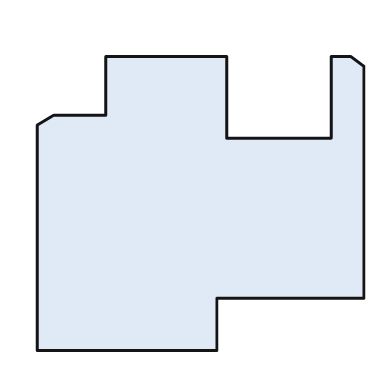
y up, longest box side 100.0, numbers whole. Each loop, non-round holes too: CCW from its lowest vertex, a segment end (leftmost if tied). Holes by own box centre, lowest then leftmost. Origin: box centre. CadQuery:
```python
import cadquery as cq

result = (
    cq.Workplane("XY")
    .moveTo(-50.0, -45.0)
    .lineTo(5.0, -45.0)
    .lineTo(5.0, -29.0)
    .lineTo(50.0, -29.0)
    .lineTo(50.0, 42.0)
    .lineTo(46.0, 45.0)
    .lineTo(40.0, 45.0)
    .lineTo(40.0, 20.0)
    .lineTo(8.0, 20.0)
    .lineTo(8.0, 45.0)
    .lineTo(-29.0, 45.0)
    .lineTo(-29.0, 27.0)
    .lineTo(-45.0, 27.0)
    .lineTo(-50.0, 24.0)
    .close()
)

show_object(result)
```